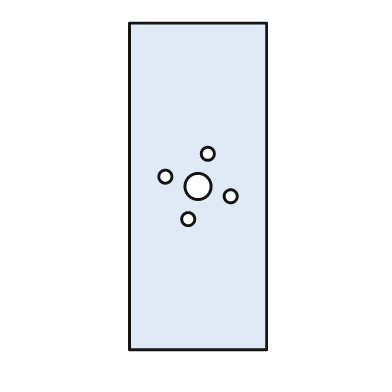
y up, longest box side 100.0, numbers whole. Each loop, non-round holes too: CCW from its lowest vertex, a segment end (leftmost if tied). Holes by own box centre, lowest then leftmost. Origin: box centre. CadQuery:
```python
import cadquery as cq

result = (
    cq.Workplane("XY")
    .moveTo(-21.0, -50.0)
    .lineTo(21.0, -50.0)
    .lineTo(21.0, 50.0)
    .lineTo(-21.0, 50.0)
    .close()
    .moveTo(-3.0, -10.0)
    .circle(2.0)
    .moveTo(10.0, -3.0)
    .circle(2.0)
    .moveTo(0.0, 0.0)
    .circle(4.0)
    .moveTo(-10.0, 3.0)
    .circle(2.0)
    .moveTo(3.0, 10.0)
    .circle(2.0)
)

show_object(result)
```